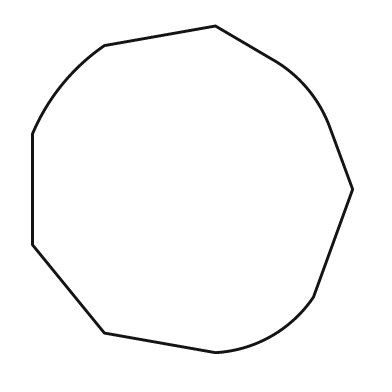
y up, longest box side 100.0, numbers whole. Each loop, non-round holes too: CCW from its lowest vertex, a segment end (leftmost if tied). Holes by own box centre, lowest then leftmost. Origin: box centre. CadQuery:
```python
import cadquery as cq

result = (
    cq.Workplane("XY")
    .moveTo(7.0, -50.0)
    .threePointArc((24.0, -45.0), (37.0, -33.0))
    .lineTo(49.0, 0.0)
    .lineTo(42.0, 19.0)
    .threePointArc((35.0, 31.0), (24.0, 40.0))
    .lineTo(7.0, 50.0)
    .lineTo(-27.0, 44.0)
    .threePointArc((-40.0, 32.0), (-49.0, 17.0))
    .lineTo(-49.0, -17.0)
    .lineTo(-27.0, -44.0)
    .close()
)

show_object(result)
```